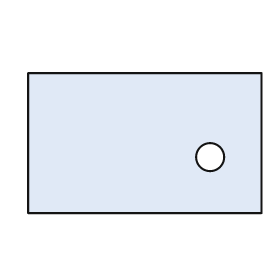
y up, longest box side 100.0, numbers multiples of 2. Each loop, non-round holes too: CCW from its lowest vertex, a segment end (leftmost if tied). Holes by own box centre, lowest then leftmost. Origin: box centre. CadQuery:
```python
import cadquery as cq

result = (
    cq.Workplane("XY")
    .moveTo(-50.0, -30.0)
    .lineTo(50.0, -30.0)
    .lineTo(50.0, 30.0)
    .lineTo(-50.0, 30.0)
    .close()
    .moveTo(28.0, -6.0)
    .circle(6.0)
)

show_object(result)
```